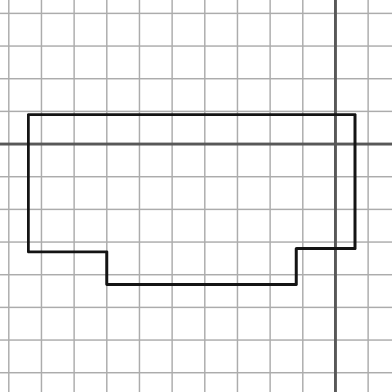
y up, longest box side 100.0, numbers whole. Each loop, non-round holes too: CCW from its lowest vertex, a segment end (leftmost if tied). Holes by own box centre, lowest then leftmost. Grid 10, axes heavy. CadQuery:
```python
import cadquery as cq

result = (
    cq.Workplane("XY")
    .moveTo(-70.0, -43.0)
    .lineTo(-12.0, -43.0)
    .lineTo(-12.0, -32.0)
    .lineTo(6.0, -32.0)
    .lineTo(6.0, 9.0)
    .lineTo(-94.0, 9.0)
    .lineTo(-94.0, -33.0)
    .lineTo(-70.0, -33.0)
    .close()
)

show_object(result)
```